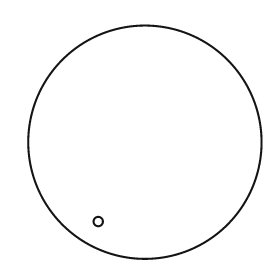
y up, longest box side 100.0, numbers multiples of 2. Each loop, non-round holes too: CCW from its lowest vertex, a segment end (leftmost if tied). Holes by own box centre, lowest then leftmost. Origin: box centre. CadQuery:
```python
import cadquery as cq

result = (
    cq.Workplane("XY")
    .moveTo(0.0, 0.0)
    .circle(50.0)
    .moveTo(-20.0, -34.0)
    .circle(2.0)
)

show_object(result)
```